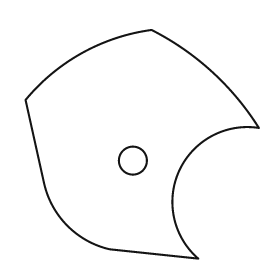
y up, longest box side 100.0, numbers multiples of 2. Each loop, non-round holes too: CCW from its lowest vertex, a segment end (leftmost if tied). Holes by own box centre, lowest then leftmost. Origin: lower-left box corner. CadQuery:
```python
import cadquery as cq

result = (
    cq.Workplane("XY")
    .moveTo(74.0, 0.0)
    .threePointArc((66.0, 38.0), (100.0, 56.0))
    .threePointArc((80.0, 80.0), (54.0, 98.0))
    .threePointArc((24.0, 88.0), (0.0, 68.0))
    .lineTo(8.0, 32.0)
    .threePointArc((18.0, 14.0), (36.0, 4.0))
    .close()
    .moveTo(46.0, 42.0)
    .circle(6.0)
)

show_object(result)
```